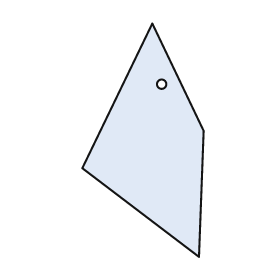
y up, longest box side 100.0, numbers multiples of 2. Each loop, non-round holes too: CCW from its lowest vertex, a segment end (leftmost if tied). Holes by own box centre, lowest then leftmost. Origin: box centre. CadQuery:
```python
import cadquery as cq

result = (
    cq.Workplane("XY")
    .moveTo(24.0, -50.0)
    .lineTo(26.0, 4.0)
    .lineTo(4.0, 50.0)
    .lineTo(-26.0, -12.0)
    .close()
    .moveTo(8.0, 24.0)
    .circle(2.0)
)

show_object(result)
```